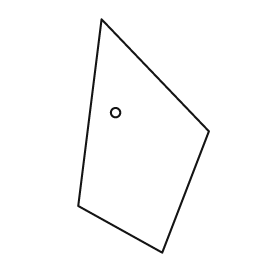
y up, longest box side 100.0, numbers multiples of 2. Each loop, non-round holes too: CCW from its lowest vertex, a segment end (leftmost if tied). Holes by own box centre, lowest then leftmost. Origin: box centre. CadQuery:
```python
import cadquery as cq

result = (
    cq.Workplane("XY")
    .moveTo(8.0, -50.0)
    .lineTo(28.0, 2.0)
    .lineTo(-18.0, 50.0)
    .lineTo(-28.0, -30.0)
    .close()
    .moveTo(-12.0, 10.0)
    .circle(2.0)
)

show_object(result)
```